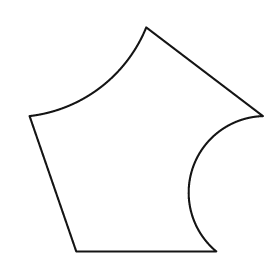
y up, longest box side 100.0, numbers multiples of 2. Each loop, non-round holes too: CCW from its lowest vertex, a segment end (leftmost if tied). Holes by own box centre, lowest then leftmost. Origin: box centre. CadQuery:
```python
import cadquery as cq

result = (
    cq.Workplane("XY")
    .moveTo(-30.0, -48.0)
    .lineTo(30.0, -48.0)
    .threePointArc((20.0, -12.0), (50.0, 10.0))
    .lineTo(0.0, 48.0)
    .threePointArc((-20.0, 22.0), (-50.0, 10.0))
    .close()
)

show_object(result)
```